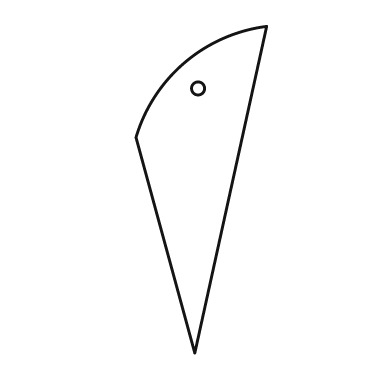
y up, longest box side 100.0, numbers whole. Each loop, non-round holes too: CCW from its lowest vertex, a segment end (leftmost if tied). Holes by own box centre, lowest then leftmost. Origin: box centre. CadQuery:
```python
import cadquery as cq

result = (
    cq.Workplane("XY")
    .moveTo(-2.0, -50.0)
    .lineTo(20.0, 50.0)
    .threePointArc((-5.0, 39.0), (-20.0, 16.0))
    .close()
    .moveTo(-1.0, 31.0)
    .circle(2.0)
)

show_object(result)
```